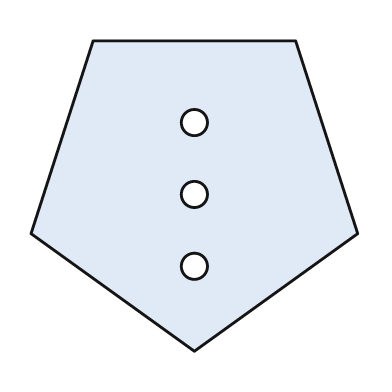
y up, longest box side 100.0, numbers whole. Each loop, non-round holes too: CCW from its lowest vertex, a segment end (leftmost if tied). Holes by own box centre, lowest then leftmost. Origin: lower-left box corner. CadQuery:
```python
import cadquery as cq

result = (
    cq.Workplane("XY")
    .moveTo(50.0, 0.0)
    .lineTo(100.0, 36.0)
    .lineTo(81.0, 95.0)
    .lineTo(19.0, 95.0)
    .lineTo(0.0, 36.0)
    .close()
    .moveTo(50.0, 26.0)
    .circle(4.0)
    .moveTo(50.0, 48.0)
    .circle(4.0)
    .moveTo(50.0, 70.0)
    .circle(4.0)
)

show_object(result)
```